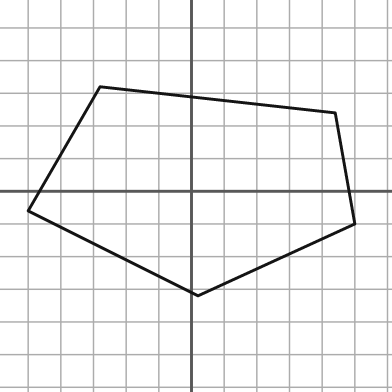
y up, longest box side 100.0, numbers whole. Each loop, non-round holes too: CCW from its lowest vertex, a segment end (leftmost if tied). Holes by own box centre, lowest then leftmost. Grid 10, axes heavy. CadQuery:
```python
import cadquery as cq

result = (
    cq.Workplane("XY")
    .moveTo(2.0, -32.0)
    .lineTo(50.0, -10.0)
    .lineTo(44.0, 24.0)
    .lineTo(-28.0, 32.0)
    .lineTo(-50.0, -6.0)
    .close()
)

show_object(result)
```